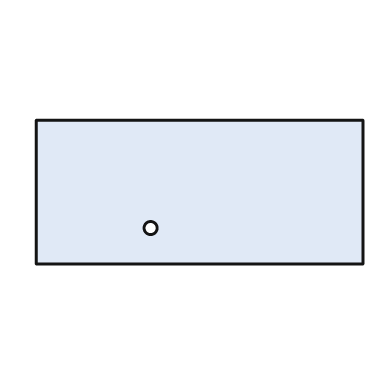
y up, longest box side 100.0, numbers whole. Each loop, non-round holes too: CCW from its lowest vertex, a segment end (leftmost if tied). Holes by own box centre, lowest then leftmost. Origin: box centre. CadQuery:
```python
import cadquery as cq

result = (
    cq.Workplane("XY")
    .moveTo(-50.0, -22.0)
    .lineTo(50.0, -22.0)
    .lineTo(50.0, 22.0)
    .lineTo(-50.0, 22.0)
    .close()
    .moveTo(-15.0, -11.0)
    .circle(2.0)
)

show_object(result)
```